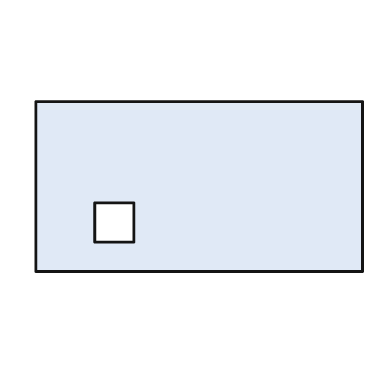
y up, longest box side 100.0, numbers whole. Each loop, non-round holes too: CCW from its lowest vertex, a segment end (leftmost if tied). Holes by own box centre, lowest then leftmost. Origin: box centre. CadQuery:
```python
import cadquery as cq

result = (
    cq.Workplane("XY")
    .moveTo(-50.0, -26.0)
    .lineTo(50.0, -26.0)
    .lineTo(50.0, 26.0)
    .lineTo(-50.0, 26.0)
    .close()
    .moveTo(-32.0, -17.0)
    .lineTo(-20.0, -17.0)
    .lineTo(-20.0, -5.0)
    .lineTo(-32.0, -5.0)
    .close()
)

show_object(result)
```